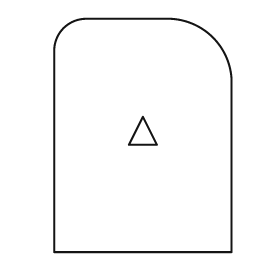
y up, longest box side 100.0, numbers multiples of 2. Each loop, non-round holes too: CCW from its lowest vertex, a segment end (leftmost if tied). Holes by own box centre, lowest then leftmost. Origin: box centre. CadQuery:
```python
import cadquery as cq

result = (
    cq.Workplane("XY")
    .moveTo(-38.0, -50.0)
    .lineTo(38.0, -50.0)
    .lineTo(38.0, 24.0)
    .threePointArc((30.0, 42.0), (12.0, 50.0))
    .lineTo(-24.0, 50.0)
    .threePointArc((-34.0, 46.0), (-38.0, 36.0))
    .close()
    .moveTo(-6.0, -4.0)
    .lineTo(6.0, -4.0)
    .lineTo(0.0, 8.0)
    .close()
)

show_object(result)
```